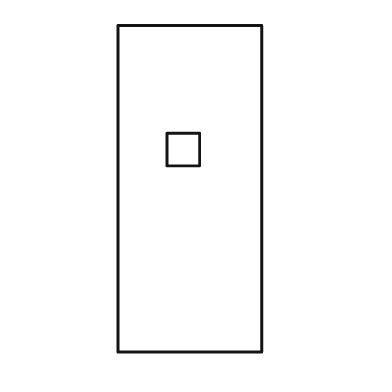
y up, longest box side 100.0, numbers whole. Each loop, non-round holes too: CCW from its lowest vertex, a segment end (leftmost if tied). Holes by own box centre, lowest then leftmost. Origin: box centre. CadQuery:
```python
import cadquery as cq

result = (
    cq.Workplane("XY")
    .moveTo(-22.0, -50.0)
    .lineTo(22.0, -50.0)
    .lineTo(22.0, 50.0)
    .lineTo(-22.0, 50.0)
    .close()
    .moveTo(-7.0, 7.0)
    .lineTo(3.0, 7.0)
    .lineTo(3.0, 17.0)
    .lineTo(-7.0, 17.0)
    .close()
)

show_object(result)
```